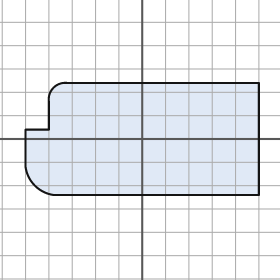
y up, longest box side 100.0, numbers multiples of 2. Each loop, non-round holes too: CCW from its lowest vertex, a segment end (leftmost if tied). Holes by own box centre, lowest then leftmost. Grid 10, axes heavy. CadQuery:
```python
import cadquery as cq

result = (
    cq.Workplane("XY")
    .moveTo(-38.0, -24.0)
    .lineTo(50.0, -24.0)
    .lineTo(50.0, 24.0)
    .lineTo(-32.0, 24.0)
    .threePointArc((-38.0, 22.0), (-40.0, 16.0))
    .lineTo(-40.0, 4.0)
    .lineTo(-50.0, 4.0)
    .lineTo(-50.0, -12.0)
    .threePointArc((-46.0, -20.0), (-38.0, -24.0))
    .close()
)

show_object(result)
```